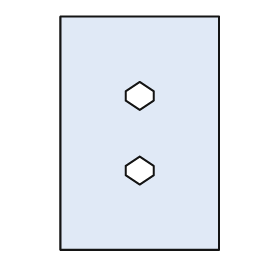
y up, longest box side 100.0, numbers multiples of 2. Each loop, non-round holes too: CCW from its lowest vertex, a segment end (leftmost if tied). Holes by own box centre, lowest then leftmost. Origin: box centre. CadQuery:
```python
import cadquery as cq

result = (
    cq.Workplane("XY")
    .moveTo(-34.0, -50.0)
    .lineTo(34.0, -50.0)
    .lineTo(34.0, 50.0)
    .lineTo(-34.0, 50.0)
    .close()
    .moveTo(0.0, -22.0)
    .lineTo(6.0, -18.0)
    .lineTo(6.0, -14.0)
    .lineTo(0.0, -10.0)
    .lineTo(-6.0, -14.0)
    .lineTo(-6.0, -18.0)
    .close()
    .moveTo(0.0, 10.0)
    .lineTo(6.0, 14.0)
    .lineTo(6.0, 18.0)
    .lineTo(0.0, 22.0)
    .lineTo(-6.0, 18.0)
    .lineTo(-6.0, 14.0)
    .close()
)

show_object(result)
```